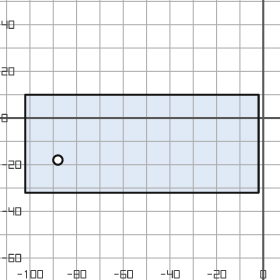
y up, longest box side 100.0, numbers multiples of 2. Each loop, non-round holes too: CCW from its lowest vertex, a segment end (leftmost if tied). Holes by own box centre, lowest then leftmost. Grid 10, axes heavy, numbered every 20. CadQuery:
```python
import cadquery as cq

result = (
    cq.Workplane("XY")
    .moveTo(-102.0, -32.0)
    .lineTo(-2.0, -32.0)
    .lineTo(-2.0, 10.0)
    .lineTo(-102.0, 10.0)
    .close()
    .moveTo(-88.0, -18.0)
    .circle(2.0)
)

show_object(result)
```